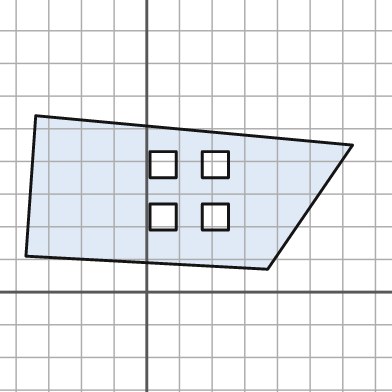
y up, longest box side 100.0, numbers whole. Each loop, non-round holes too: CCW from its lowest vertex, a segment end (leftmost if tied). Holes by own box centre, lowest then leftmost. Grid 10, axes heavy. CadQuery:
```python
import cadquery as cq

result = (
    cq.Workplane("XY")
    .moveTo(37.0, 7.0)
    .lineTo(63.0, 45.0)
    .lineTo(-34.0, 54.0)
    .lineTo(-37.0, 11.0)
    .close()
    .moveTo(1.0, 19.0)
    .lineTo(9.0, 19.0)
    .lineTo(9.0, 27.0)
    .lineTo(1.0, 27.0)
    .close()
    .moveTo(17.0, 19.0)
    .lineTo(25.0, 19.0)
    .lineTo(25.0, 27.0)
    .lineTo(17.0, 27.0)
    .close()
    .moveTo(1.0, 35.0)
    .lineTo(9.0, 35.0)
    .lineTo(9.0, 43.0)
    .lineTo(1.0, 43.0)
    .close()
    .moveTo(17.0, 35.0)
    .lineTo(25.0, 35.0)
    .lineTo(25.0, 43.0)
    .lineTo(17.0, 43.0)
    .close()
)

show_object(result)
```